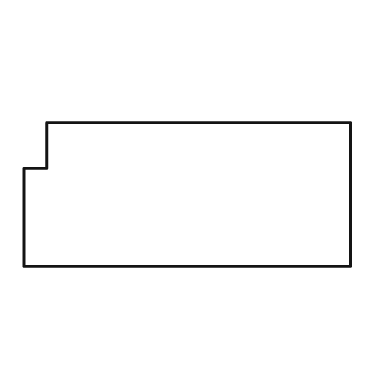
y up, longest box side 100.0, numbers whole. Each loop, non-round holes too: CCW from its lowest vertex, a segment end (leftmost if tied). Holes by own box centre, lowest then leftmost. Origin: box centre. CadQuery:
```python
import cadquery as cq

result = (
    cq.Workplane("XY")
    .moveTo(-50.0, -22.0)
    .lineTo(50.0, -22.0)
    .lineTo(50.0, 22.0)
    .lineTo(-43.0, 22.0)
    .lineTo(-43.0, 8.0)
    .lineTo(-50.0, 8.0)
    .close()
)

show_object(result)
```